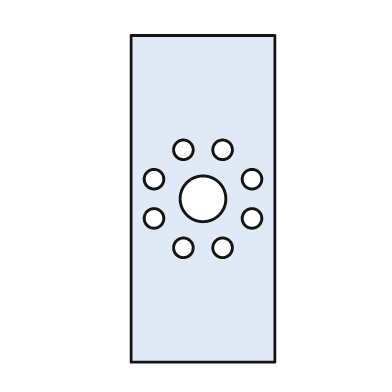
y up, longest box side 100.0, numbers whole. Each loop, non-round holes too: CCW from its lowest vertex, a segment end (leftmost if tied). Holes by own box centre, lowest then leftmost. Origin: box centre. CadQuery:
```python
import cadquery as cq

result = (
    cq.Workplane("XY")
    .moveTo(-22.0, -50.0)
    .lineTo(22.0, -50.0)
    .lineTo(22.0, 50.0)
    .lineTo(-22.0, 50.0)
    .close()
    .moveTo(-6.0, -15.0)
    .circle(3.0)
    .moveTo(6.0, -15.0)
    .circle(3.0)
    .moveTo(-15.0, -6.0)
    .circle(3.0)
    .moveTo(15.0, -6.0)
    .circle(3.0)
    .moveTo(0.0, 0.0)
    .circle(7.0)
    .moveTo(-15.0, 6.0)
    .circle(3.0)
    .moveTo(15.0, 6.0)
    .circle(3.0)
    .moveTo(-6.0, 15.0)
    .circle(3.0)
    .moveTo(6.0, 15.0)
    .circle(3.0)
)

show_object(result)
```